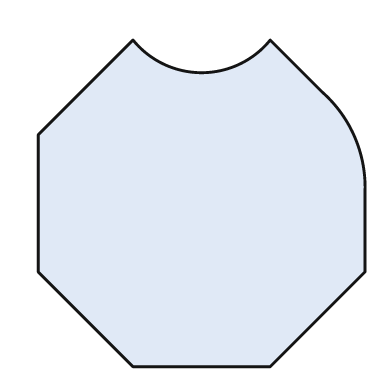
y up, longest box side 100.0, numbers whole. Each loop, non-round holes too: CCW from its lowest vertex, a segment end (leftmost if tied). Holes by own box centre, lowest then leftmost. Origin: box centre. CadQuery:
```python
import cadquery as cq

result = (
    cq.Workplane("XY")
    .moveTo(-21.0, -50.0)
    .lineTo(21.0, -50.0)
    .lineTo(50.0, -21.0)
    .lineTo(50.0, 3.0)
    .threePointArc((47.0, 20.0), (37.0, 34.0))
    .lineTo(21.0, 50.0)
    .threePointArc((0.0, 40.0), (-21.0, 50.0))
    .lineTo(-50.0, 21.0)
    .lineTo(-50.0, -21.0)
    .close()
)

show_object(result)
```